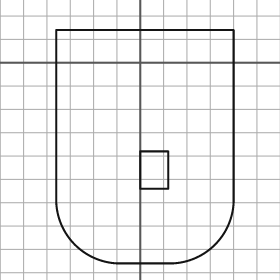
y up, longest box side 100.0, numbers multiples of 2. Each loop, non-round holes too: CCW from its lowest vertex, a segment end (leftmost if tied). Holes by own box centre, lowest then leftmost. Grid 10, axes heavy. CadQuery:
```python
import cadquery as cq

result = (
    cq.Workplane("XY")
    .moveTo(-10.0, -86.0)
    .lineTo(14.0, -86.0)
    .threePointArc((32.0, -78.0), (40.0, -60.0))
    .lineTo(40.0, 14.0)
    .lineTo(-36.0, 14.0)
    .lineTo(-36.0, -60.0)
    .threePointArc((-28.0, -78.0), (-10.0, -86.0))
    .close()
    .moveTo(0.0, -54.0)
    .lineTo(12.0, -54.0)
    .lineTo(12.0, -38.0)
    .lineTo(0.0, -38.0)
    .close()
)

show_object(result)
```